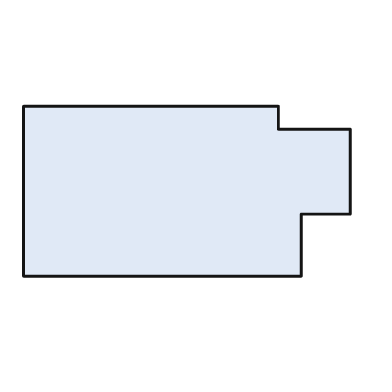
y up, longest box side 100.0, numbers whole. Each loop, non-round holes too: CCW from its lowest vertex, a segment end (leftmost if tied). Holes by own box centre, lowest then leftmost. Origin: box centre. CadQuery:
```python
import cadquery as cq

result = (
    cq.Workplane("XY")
    .moveTo(-50.0, -26.0)
    .lineTo(35.0, -26.0)
    .lineTo(35.0, -7.0)
    .lineTo(50.0, -7.0)
    .lineTo(50.0, 19.0)
    .lineTo(28.0, 19.0)
    .lineTo(28.0, 26.0)
    .lineTo(-50.0, 26.0)
    .close()
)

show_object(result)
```